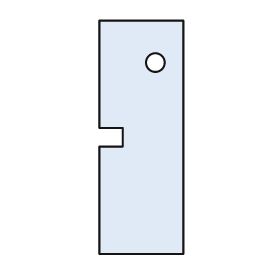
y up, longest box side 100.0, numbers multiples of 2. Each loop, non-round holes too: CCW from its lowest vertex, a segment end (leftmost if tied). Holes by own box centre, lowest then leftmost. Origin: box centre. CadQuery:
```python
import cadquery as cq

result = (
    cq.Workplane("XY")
    .moveTo(-18.0, -50.0)
    .lineTo(18.0, -50.0)
    .lineTo(18.0, 50.0)
    .lineTo(-18.0, 50.0)
    .lineTo(-18.0, 4.0)
    .lineTo(-8.0, 4.0)
    .lineTo(-8.0, -4.0)
    .lineTo(-18.0, -4.0)
    .close()
    .moveTo(6.0, 32.0)
    .circle(4.0)
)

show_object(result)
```